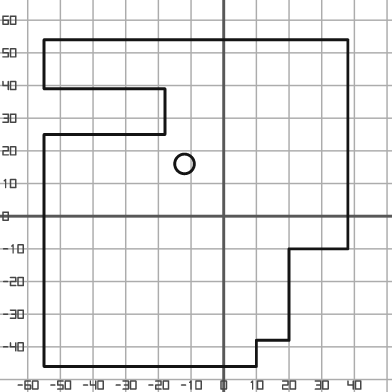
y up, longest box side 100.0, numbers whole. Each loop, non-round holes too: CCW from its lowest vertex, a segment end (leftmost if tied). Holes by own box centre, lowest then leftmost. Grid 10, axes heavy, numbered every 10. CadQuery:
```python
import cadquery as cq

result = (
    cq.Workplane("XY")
    .moveTo(-55.0, -46.0)
    .lineTo(10.0, -46.0)
    .lineTo(10.0, -38.0)
    .lineTo(20.0, -38.0)
    .lineTo(20.0, -10.0)
    .lineTo(38.0, -10.0)
    .lineTo(38.0, 54.0)
    .lineTo(-55.0, 54.0)
    .lineTo(-55.0, 39.0)
    .lineTo(-18.0, 39.0)
    .lineTo(-18.0, 25.0)
    .lineTo(-55.0, 25.0)
    .close()
    .moveTo(-12.0, 16.0)
    .circle(3.0)
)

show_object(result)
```